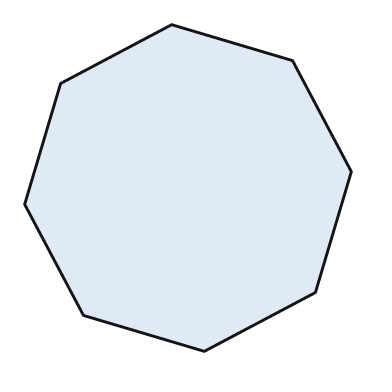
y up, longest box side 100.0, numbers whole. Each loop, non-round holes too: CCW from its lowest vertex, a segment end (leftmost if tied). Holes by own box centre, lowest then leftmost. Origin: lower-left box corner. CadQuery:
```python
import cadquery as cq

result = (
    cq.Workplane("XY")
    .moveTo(55.0, 0.0)
    .lineTo(89.0, 18.0)
    .lineTo(100.0, 55.0)
    .lineTo(82.0, 89.0)
    .lineTo(45.0, 100.0)
    .lineTo(11.0, 82.0)
    .lineTo(0.0, 45.0)
    .lineTo(18.0, 11.0)
    .close()
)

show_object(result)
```